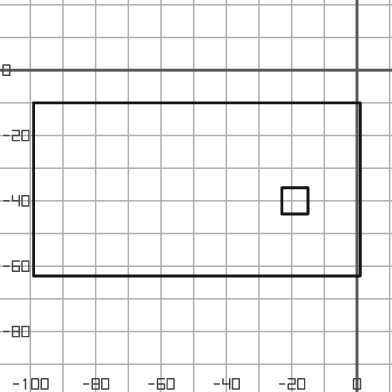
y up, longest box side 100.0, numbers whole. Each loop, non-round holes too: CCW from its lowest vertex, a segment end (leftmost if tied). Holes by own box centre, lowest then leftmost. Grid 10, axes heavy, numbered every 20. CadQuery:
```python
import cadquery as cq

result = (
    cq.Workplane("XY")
    .moveTo(-99.0, -63.0)
    .lineTo(1.0, -63.0)
    .lineTo(1.0, -10.0)
    .lineTo(-99.0, -10.0)
    .close()
    .moveTo(-23.0, -44.0)
    .lineTo(-15.0, -44.0)
    .lineTo(-15.0, -36.0)
    .lineTo(-23.0, -36.0)
    .close()
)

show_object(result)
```